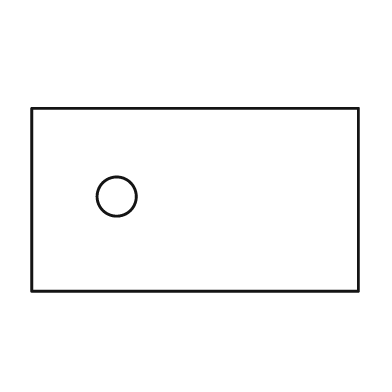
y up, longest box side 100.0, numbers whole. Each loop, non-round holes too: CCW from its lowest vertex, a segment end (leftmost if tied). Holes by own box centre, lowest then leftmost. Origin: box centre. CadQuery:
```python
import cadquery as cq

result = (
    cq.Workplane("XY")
    .moveTo(-50.0, -28.0)
    .lineTo(50.0, -28.0)
    .lineTo(50.0, 28.0)
    .lineTo(-50.0, 28.0)
    .close()
    .moveTo(-24.0, 1.0)
    .circle(6.0)
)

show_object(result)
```